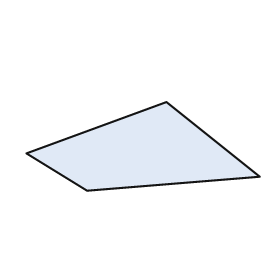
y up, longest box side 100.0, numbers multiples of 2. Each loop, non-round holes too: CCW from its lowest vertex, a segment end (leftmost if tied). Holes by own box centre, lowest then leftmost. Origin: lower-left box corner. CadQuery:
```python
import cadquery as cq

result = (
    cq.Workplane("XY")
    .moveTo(26.0, 0.0)
    .lineTo(100.0, 6.0)
    .lineTo(60.0, 38.0)
    .lineTo(0.0, 16.0)
    .close()
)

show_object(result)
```